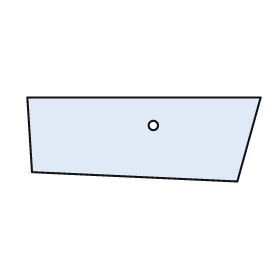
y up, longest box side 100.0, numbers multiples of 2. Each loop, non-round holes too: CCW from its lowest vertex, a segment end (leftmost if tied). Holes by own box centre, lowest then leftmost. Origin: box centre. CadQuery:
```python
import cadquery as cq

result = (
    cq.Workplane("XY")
    .moveTo(40.0, -18.0)
    .lineTo(50.0, 18.0)
    .lineTo(-50.0, 18.0)
    .lineTo(-48.0, -14.0)
    .close()
    .moveTo(4.0, 6.0)
    .circle(2.0)
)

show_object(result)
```